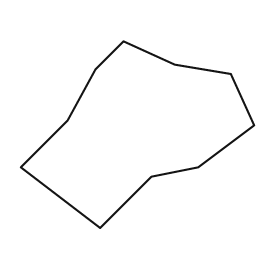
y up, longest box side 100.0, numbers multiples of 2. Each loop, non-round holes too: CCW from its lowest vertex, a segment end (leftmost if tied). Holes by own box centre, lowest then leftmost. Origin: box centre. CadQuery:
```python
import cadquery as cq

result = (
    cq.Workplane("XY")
    .moveTo(-16.0, -40.0)
    .lineTo(6.0, -18.0)
    .lineTo(26.0, -14.0)
    .lineTo(50.0, 4.0)
    .lineTo(40.0, 26.0)
    .lineTo(16.0, 30.0)
    .lineTo(-6.0, 40.0)
    .lineTo(-18.0, 28.0)
    .lineTo(-30.0, 6.0)
    .lineTo(-50.0, -14.0)
    .close()
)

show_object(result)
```